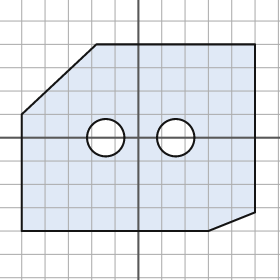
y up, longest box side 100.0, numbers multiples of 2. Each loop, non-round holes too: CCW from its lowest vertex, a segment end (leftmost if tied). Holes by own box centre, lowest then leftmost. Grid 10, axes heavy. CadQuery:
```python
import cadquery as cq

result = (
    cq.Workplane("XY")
    .moveTo(-50.0, -40.0)
    .lineTo(30.0, -40.0)
    .lineTo(50.0, -32.0)
    .lineTo(50.0, 40.0)
    .lineTo(-18.0, 40.0)
    .lineTo(-50.0, 10.0)
    .close()
    .moveTo(-14.0, 0.0)
    .circle(8.0)
    .moveTo(16.0, 0.0)
    .circle(8.0)
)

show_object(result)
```